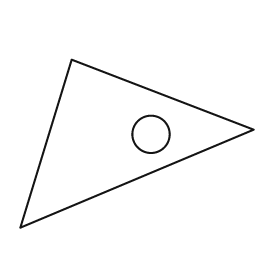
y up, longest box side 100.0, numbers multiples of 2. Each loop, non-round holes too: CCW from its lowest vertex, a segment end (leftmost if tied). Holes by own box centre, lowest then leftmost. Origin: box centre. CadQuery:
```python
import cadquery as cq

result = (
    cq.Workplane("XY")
    .moveTo(-50.0, -36.0)
    .lineTo(50.0, 6.0)
    .lineTo(-28.0, 36.0)
    .close()
    .moveTo(6.0, 4.0)
    .circle(8.0)
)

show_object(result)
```